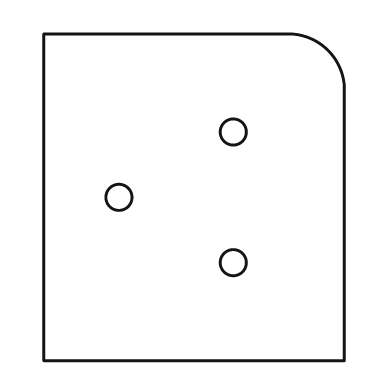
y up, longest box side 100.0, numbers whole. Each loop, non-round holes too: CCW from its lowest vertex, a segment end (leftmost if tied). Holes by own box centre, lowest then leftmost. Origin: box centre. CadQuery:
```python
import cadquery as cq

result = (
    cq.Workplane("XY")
    .moveTo(-46.0, -50.0)
    .lineTo(46.0, -50.0)
    .lineTo(46.0, 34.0)
    .threePointArc((41.0, 45.0), (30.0, 50.0))
    .lineTo(-46.0, 50.0)
    .close()
    .moveTo(12.0, -20.0)
    .circle(4.0)
    .moveTo(-23.0, 0.0)
    .circle(4.0)
    .moveTo(12.0, 20.0)
    .circle(4.0)
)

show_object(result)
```